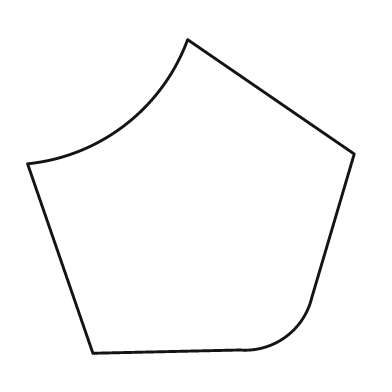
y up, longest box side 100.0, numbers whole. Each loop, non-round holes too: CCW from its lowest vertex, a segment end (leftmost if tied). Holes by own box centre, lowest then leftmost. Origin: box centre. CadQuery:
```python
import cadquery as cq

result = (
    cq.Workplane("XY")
    .moveTo(-30.0, -48.0)
    .lineTo(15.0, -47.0)
    .threePointArc((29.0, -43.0), (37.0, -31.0))
    .lineTo(50.0, 13.0)
    .lineTo(-1.0, 48.0)
    .threePointArc((-20.0, 22.0), (-50.0, 10.0))
    .close()
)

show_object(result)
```